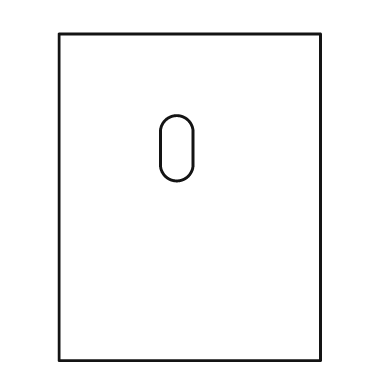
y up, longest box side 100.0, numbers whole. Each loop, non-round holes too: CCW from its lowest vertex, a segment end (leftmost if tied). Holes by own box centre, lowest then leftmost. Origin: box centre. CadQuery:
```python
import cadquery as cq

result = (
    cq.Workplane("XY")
    .moveTo(-40.0, -50.0)
    .lineTo(40.0, -50.0)
    .lineTo(40.0, 50.0)
    .lineTo(-40.0, 50.0)
    .close()
    .moveTo(-9.0, 10.0)
    .threePointArc((-4.0, 5.0), (1.0, 10.0))
    .lineTo(1.0, 20.0)
    .threePointArc((-4.0, 25.0), (-9.0, 20.0))
    .close()
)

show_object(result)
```